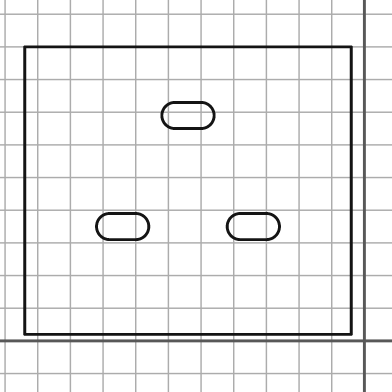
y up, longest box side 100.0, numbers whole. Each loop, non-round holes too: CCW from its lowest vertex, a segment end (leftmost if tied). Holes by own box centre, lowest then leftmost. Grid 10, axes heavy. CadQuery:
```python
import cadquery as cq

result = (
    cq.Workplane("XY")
    .moveTo(-104.0, 2.0)
    .lineTo(-4.0, 2.0)
    .lineTo(-4.0, 90.0)
    .lineTo(-104.0, 90.0)
    .close()
    .moveTo(-78.0, 31.0)
    .lineTo(-70.0, 31.0)
    .threePointArc((-66.0, 35.0), (-70.0, 39.0))
    .lineTo(-78.0, 39.0)
    .threePointArc((-82.0, 35.0), (-78.0, 31.0))
    .close()
    .moveTo(-38.0, 31.0)
    .lineTo(-30.0, 31.0)
    .threePointArc((-26.0, 35.0), (-30.0, 39.0))
    .lineTo(-38.0, 39.0)
    .threePointArc((-42.0, 35.0), (-38.0, 31.0))
    .close()
    .moveTo(-58.0, 65.0)
    .lineTo(-50.0, 65.0)
    .threePointArc((-46.0, 69.0), (-50.0, 73.0))
    .lineTo(-58.0, 73.0)
    .threePointArc((-62.0, 69.0), (-58.0, 65.0))
    .close()
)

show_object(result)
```